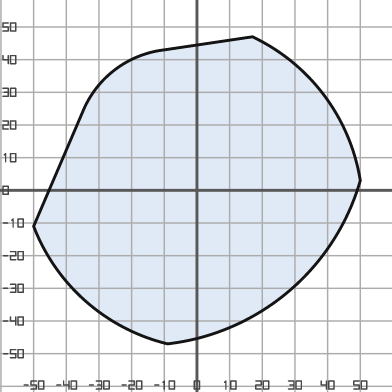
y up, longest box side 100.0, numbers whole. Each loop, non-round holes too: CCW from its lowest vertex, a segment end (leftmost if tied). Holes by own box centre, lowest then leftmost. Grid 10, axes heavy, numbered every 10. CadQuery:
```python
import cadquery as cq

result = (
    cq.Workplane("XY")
    .moveTo(-9.0, -47.0)
    .threePointArc((28.0, -31.0), (50.0, 3.0))
    .threePointArc((39.0, 29.0), (17.0, 47.0))
    .lineTo(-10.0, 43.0)
    .threePointArc((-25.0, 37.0), (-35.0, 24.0))
    .lineTo(-50.0, -11.0)
    .threePointArc((-34.0, -34.0), (-9.0, -47.0))
    .close()
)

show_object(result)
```